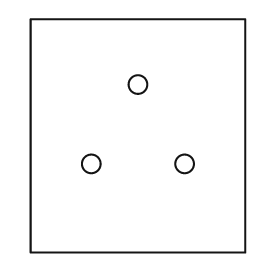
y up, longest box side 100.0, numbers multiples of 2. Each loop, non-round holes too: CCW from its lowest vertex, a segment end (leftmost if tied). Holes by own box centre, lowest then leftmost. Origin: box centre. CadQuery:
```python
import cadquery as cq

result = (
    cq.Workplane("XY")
    .moveTo(-46.0, -50.0)
    .lineTo(46.0, -50.0)
    .lineTo(46.0, 50.0)
    .lineTo(-46.0, 50.0)
    .close()
    .moveTo(-20.0, -12.0)
    .circle(4.0)
    .moveTo(20.0, -12.0)
    .circle(4.0)
    .moveTo(0.0, 22.0)
    .circle(4.0)
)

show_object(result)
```